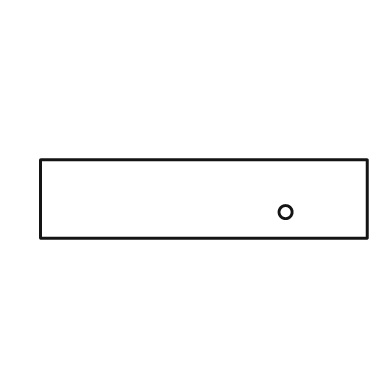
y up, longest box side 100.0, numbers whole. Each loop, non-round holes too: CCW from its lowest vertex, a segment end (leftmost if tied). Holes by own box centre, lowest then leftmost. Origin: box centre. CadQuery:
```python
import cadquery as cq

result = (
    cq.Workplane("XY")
    .moveTo(-50.0, -12.0)
    .lineTo(50.0, -12.0)
    .lineTo(50.0, 12.0)
    .lineTo(-50.0, 12.0)
    .close()
    .moveTo(25.0, -4.0)
    .circle(2.0)
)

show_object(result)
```